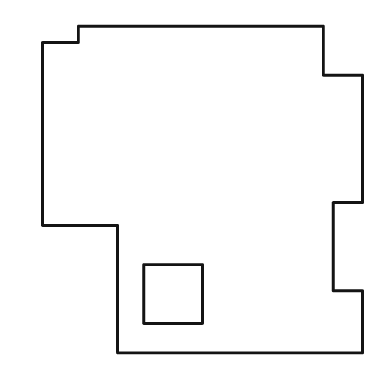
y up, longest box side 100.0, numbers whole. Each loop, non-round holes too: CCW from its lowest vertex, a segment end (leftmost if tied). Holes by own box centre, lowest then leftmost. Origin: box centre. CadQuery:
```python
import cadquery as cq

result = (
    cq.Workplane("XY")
    .moveTo(-26.0, -50.0)
    .lineTo(49.0, -50.0)
    .lineTo(49.0, -31.0)
    .lineTo(40.0, -31.0)
    .lineTo(40.0, -4.0)
    .lineTo(49.0, -4.0)
    .lineTo(49.0, 35.0)
    .lineTo(37.0, 35.0)
    .lineTo(37.0, 50.0)
    .lineTo(-38.0, 50.0)
    .lineTo(-38.0, 45.0)
    .lineTo(-49.0, 45.0)
    .lineTo(-49.0, -11.0)
    .lineTo(-26.0, -11.0)
    .close()
    .moveTo(-18.0, -41.0)
    .lineTo(0.0, -41.0)
    .lineTo(0.0, -23.0)
    .lineTo(-18.0, -23.0)
    .close()
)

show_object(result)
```